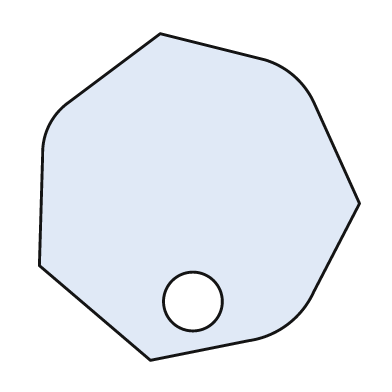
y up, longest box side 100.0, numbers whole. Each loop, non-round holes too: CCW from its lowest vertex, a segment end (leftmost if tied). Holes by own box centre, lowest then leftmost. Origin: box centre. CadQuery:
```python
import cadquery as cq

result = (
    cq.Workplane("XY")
    .moveTo(-15.0, -50.0)
    .lineTo(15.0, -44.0)
    .threePointArc((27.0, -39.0), (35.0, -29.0))
    .lineTo(49.0, -2.0)
    .lineTo(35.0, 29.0)
    .threePointArc((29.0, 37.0), (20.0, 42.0))
    .lineTo(-12.0, 50.0)
    .lineTo(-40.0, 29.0)
    .threePointArc((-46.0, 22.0), (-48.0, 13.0))
    .lineTo(-49.0, -21.0)
    .close()
    .moveTo(-2.0, -32.0)
    .circle(9.0)
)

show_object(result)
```